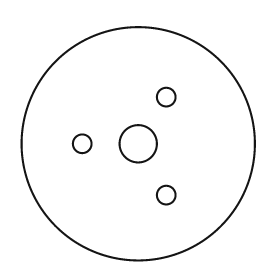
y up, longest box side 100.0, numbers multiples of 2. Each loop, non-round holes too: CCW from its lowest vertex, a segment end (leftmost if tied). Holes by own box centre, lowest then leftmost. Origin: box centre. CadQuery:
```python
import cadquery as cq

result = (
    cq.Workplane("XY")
    .moveTo(0.0, 0.0)
    .circle(50.0)
    .moveTo(12.0, -22.0)
    .circle(4.0)
    .moveTo(-24.0, 0.0)
    .circle(4.0)
    .moveTo(0.0, 0.0)
    .circle(8.0)
    .moveTo(12.0, 20.0)
    .circle(4.0)
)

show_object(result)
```